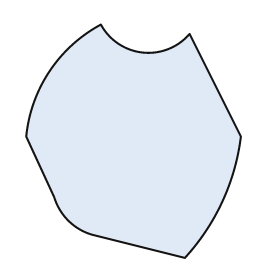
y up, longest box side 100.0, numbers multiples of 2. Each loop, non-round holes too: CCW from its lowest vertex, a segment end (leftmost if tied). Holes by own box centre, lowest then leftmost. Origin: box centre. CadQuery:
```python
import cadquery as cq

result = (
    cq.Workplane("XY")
    .moveTo(22.0, -50.0)
    .threePointArc((38.0, -26.0), (46.0, 2.0))
    .lineTo(24.0, 46.0)
    .threePointArc((4.0, 38.0), (-14.0, 50.0))
    .threePointArc((-36.0, 30.0), (-46.0, 2.0))
    .lineTo(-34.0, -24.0)
    .threePointArc((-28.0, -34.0), (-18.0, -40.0))
    .close()
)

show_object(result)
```